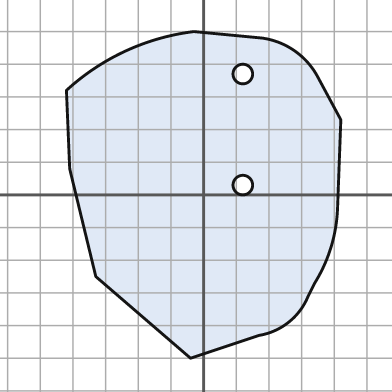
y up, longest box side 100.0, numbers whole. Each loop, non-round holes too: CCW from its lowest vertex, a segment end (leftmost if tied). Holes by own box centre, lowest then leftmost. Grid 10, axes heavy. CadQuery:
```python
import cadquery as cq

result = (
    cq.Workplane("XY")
    .moveTo(-4.0, -50.0)
    .lineTo(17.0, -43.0)
    .threePointArc((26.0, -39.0), (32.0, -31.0))
    .lineTo(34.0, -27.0)
    .threePointArc((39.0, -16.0), (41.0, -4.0))
    .lineTo(42.0, 23.0)
    .lineTo(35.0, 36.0)
    .threePointArc((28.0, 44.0), (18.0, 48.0))
    .lineTo(-3.0, 50.0)
    .threePointArc((-24.0, 44.0), (-42.0, 32.0))
    .lineTo(-41.0, 8.0)
    .lineTo(-33.0, -25.0)
    .close()
    .moveTo(12.0, 3.0)
    .circle(3.0)
    .moveTo(12.0, 37.0)
    .circle(3.0)
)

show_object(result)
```